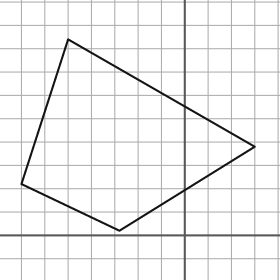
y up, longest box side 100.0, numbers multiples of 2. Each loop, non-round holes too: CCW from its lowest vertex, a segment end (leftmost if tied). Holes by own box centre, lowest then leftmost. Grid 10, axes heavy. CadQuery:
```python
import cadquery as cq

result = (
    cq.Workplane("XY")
    .moveTo(-28.0, 2.0)
    .lineTo(30.0, 38.0)
    .lineTo(-50.0, 84.0)
    .lineTo(-70.0, 22.0)
    .close()
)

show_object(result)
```